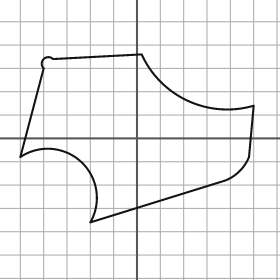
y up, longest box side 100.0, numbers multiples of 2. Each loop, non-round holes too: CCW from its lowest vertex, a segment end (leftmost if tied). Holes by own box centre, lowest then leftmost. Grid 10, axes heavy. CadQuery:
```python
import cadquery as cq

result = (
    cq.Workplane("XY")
    .moveTo(-20.0, -36.0)
    .lineTo(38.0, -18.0)
    .threePointArc((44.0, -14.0), (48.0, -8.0))
    .lineTo(50.0, 14.0)
    .threePointArc((22.0, 16.0), (2.0, 36.0))
    .lineTo(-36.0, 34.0)
    .threePointArc((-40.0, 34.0), (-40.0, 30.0))
    .lineTo(-50.0, -8.0)
    .threePointArc((-24.0, -10.0), (-20.0, -36.0))
    .close()
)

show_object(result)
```